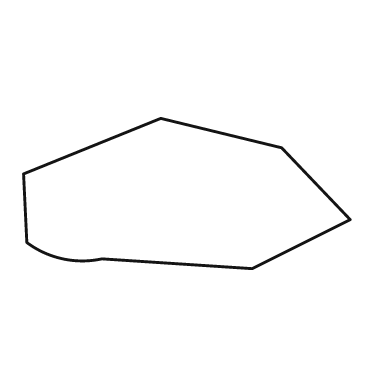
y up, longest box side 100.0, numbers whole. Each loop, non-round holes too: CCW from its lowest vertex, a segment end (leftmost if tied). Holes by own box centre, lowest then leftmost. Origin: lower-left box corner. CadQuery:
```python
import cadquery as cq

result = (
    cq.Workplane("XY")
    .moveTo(70.0, 0.0)
    .lineTo(100.0, 15.0)
    .lineTo(79.0, 37.0)
    .lineTo(42.0, 46.0)
    .lineTo(0.0, 29.0)
    .lineTo(1.0, 8.0)
    .threePointArc((12.0, 3.0), (24.0, 3.0))
    .close()
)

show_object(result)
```